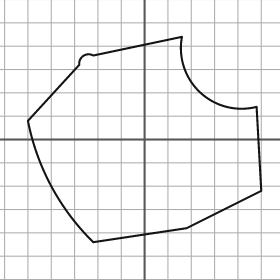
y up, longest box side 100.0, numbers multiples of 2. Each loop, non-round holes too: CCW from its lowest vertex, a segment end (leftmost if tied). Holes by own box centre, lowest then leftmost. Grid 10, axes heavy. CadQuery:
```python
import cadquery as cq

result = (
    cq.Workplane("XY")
    .moveTo(-22.0, -44.0)
    .lineTo(18.0, -38.0)
    .lineTo(50.0, -22.0)
    .lineTo(48.0, 14.0)
    .threePointArc((24.0, 20.0), (16.0, 44.0))
    .lineTo(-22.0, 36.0)
    .threePointArc((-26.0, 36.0), (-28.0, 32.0))
    .lineTo(-50.0, 8.0)
    .threePointArc((-40.0, -20.0), (-22.0, -44.0))
    .close()
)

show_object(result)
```